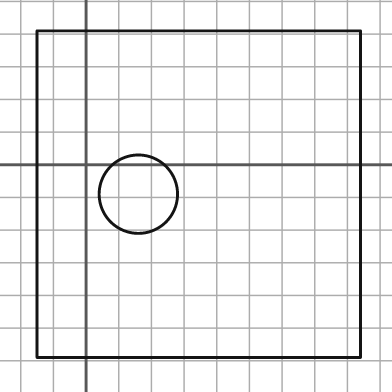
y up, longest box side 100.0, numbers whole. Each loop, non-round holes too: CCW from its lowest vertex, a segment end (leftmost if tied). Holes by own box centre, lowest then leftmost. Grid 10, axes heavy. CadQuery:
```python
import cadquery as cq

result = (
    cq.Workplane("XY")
    .moveTo(-15.0, -59.0)
    .lineTo(84.0, -59.0)
    .lineTo(84.0, 41.0)
    .lineTo(-15.0, 41.0)
    .close()
    .moveTo(16.0, -9.0)
    .circle(12.0)
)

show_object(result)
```